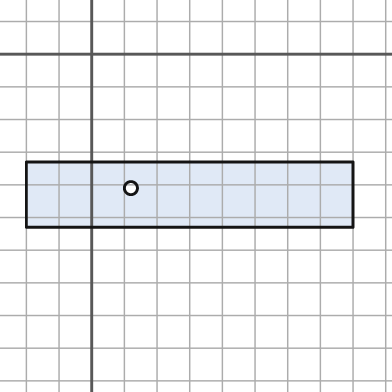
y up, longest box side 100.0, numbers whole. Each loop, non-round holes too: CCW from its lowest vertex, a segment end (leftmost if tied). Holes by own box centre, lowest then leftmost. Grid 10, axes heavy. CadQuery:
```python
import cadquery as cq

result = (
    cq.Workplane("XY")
    .moveTo(-20.0, -53.0)
    .lineTo(80.0, -53.0)
    .lineTo(80.0, -33.0)
    .lineTo(-20.0, -33.0)
    .close()
    .moveTo(12.0, -41.0)
    .circle(2.0)
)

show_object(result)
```